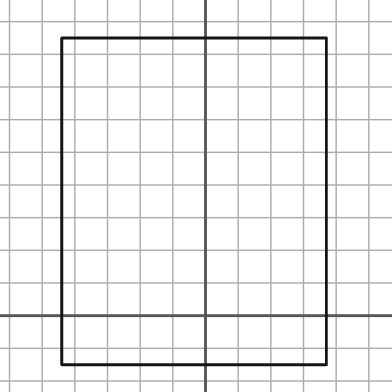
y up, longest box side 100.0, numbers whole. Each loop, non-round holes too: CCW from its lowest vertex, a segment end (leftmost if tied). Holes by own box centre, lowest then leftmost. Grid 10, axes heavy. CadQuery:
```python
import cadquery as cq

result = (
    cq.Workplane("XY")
    .moveTo(-44.0, -15.0)
    .lineTo(37.0, -15.0)
    .lineTo(37.0, 85.0)
    .lineTo(-44.0, 85.0)
    .close()
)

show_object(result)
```